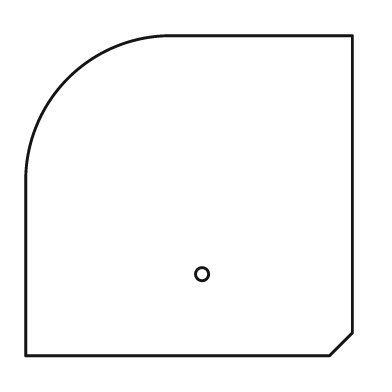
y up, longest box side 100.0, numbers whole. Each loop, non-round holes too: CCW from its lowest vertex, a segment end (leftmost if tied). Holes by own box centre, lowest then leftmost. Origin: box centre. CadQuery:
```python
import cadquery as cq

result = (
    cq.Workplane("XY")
    .moveTo(-50.0, -49.0)
    .lineTo(43.0, -49.0)
    .lineTo(50.0, -42.0)
    .lineTo(50.0, 49.0)
    .lineTo(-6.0, 49.0)
    .threePointArc((-37.0, 36.0), (-50.0, 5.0))
    .close()
    .moveTo(4.0, -24.0)
    .circle(2.0)
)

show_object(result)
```